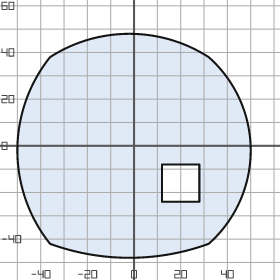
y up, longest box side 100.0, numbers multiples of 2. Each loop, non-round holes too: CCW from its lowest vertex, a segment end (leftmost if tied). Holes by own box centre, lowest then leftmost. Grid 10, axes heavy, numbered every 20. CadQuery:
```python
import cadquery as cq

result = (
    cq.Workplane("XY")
    .moveTo(-36.0, -42.0)
    .threePointArc((-2.0, -48.0), (32.0, -42.0))
    .threePointArc((50.0, -2.0), (32.0, 38.0))
    .threePointArc((-2.0, 48.0), (-36.0, 38.0))
    .threePointArc((-50.0, -2.0), (-36.0, -42.0))
    .close()
    .moveTo(12.0, -24.0)
    .lineTo(28.0, -24.0)
    .lineTo(28.0, -8.0)
    .lineTo(12.0, -8.0)
    .close()
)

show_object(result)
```